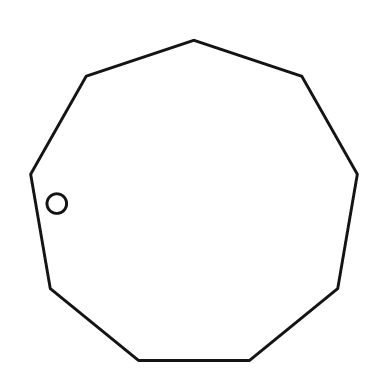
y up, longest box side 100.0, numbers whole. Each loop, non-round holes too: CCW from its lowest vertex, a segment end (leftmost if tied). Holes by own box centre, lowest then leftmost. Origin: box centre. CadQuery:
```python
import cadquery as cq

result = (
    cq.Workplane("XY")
    .moveTo(-17.0, -49.0)
    .lineTo(17.0, -49.0)
    .lineTo(44.0, -27.0)
    .lineTo(50.0, 8.0)
    .lineTo(33.0, 38.0)
    .lineTo(0.0, 49.0)
    .lineTo(-33.0, 38.0)
    .lineTo(-50.0, 8.0)
    .lineTo(-44.0, -27.0)
    .close()
    .moveTo(-42.0, -1.0)
    .circle(3.0)
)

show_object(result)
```